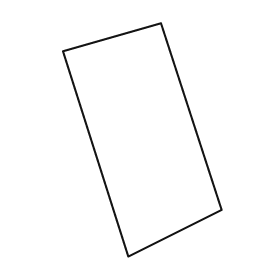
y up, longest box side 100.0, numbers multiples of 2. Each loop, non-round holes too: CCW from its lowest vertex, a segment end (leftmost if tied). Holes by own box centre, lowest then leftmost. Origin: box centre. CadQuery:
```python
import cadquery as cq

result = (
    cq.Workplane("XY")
    .moveTo(-6.0, -50.0)
    .lineTo(34.0, -30.0)
    .lineTo(8.0, 50.0)
    .lineTo(-34.0, 38.0)
    .close()
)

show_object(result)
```